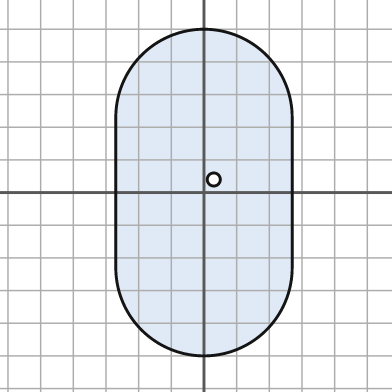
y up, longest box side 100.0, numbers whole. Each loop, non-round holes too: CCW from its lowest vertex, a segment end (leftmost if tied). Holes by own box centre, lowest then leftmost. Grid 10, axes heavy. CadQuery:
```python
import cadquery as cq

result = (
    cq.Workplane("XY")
    .moveTo(-27.0, -23.0)
    .threePointArc((0.0, -50.0), (27.0, -23.0))
    .lineTo(27.0, 23.0)
    .threePointArc((0.0, 50.0), (-27.0, 23.0))
    .close()
    .moveTo(3.0, 4.0)
    .circle(2.0)
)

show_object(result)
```